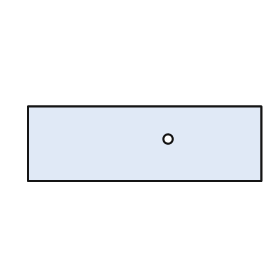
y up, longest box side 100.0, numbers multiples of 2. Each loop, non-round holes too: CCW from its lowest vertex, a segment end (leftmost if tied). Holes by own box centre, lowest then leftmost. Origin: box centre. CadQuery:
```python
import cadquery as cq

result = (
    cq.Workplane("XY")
    .moveTo(-50.0, -16.0)
    .lineTo(50.0, -16.0)
    .lineTo(50.0, 16.0)
    .lineTo(-50.0, 16.0)
    .close()
    .moveTo(10.0, 2.0)
    .circle(2.0)
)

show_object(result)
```